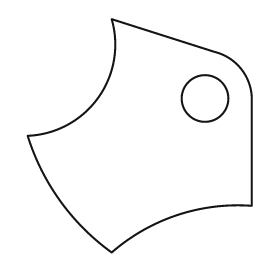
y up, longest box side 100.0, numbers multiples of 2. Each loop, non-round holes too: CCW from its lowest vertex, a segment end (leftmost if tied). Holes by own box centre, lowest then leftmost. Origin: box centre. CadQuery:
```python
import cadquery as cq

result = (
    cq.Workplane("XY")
    .moveTo(-12.0, -50.0)
    .threePointArc((16.0, -34.0), (48.0, -30.0))
    .lineTo(48.0, 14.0)
    .threePointArc((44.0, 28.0), (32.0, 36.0))
    .lineTo(-12.0, 50.0)
    .threePointArc((-18.0, 16.0), (-48.0, 0.0))
    .threePointArc((-34.0, -28.0), (-12.0, -50.0))
    .close()
    .moveTo(28.0, 16.0)
    .circle(10.0)
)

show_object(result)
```